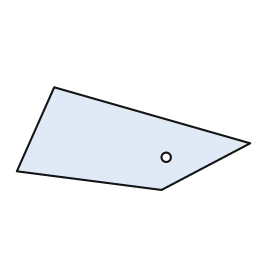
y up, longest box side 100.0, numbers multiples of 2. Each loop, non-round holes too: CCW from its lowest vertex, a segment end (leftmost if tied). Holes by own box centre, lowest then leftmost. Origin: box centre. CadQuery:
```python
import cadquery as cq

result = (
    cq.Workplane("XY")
    .moveTo(12.0, -22.0)
    .lineTo(50.0, -2.0)
    .lineTo(-34.0, 22.0)
    .lineTo(-50.0, -14.0)
    .close()
    .moveTo(14.0, -8.0)
    .circle(2.0)
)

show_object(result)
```